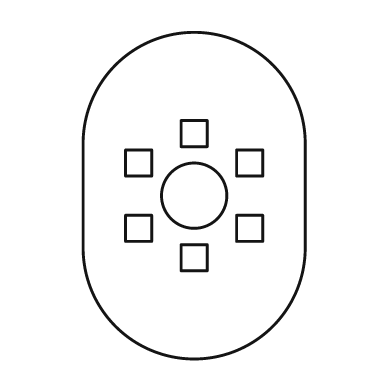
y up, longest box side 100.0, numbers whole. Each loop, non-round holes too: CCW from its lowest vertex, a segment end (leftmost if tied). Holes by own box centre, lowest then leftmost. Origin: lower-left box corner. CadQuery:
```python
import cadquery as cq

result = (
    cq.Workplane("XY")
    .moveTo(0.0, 34.0)
    .threePointArc((34.0, 0.0), (68.0, 34.0))
    .lineTo(68.0, 66.0)
    .threePointArc((34.0, 100.0), (0.0, 66.0))
    .close()
    .moveTo(30.0, 27.0)
    .lineTo(38.0, 27.0)
    .lineTo(38.0, 35.0)
    .lineTo(30.0, 35.0)
    .close()
    .moveTo(13.0, 36.0)
    .lineTo(21.0, 36.0)
    .lineTo(21.0, 44.0)
    .lineTo(13.0, 44.0)
    .close()
    .moveTo(47.0, 36.0)
    .lineTo(55.0, 36.0)
    .lineTo(55.0, 44.0)
    .lineTo(47.0, 44.0)
    .close()
    .moveTo(34.0, 50.0)
    .circle(10.0)
    .moveTo(13.0, 56.0)
    .lineTo(21.0, 56.0)
    .lineTo(21.0, 64.0)
    .lineTo(13.0, 64.0)
    .close()
    .moveTo(47.0, 56.0)
    .lineTo(55.0, 56.0)
    .lineTo(55.0, 64.0)
    .lineTo(47.0, 64.0)
    .close()
    .moveTo(30.0, 65.0)
    .lineTo(38.0, 65.0)
    .lineTo(38.0, 73.0)
    .lineTo(30.0, 73.0)
    .close()
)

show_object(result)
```